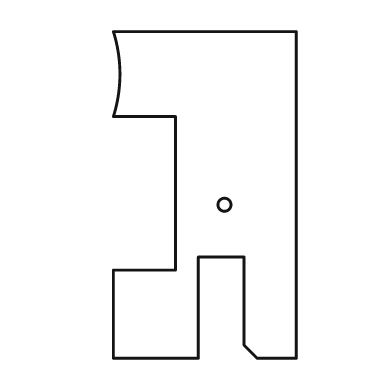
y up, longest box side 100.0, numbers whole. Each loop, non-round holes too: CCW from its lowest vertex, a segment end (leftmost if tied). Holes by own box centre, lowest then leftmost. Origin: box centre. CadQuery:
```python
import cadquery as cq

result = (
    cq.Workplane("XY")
    .moveTo(-28.0, -50.0)
    .lineTo(-2.0, -50.0)
    .lineTo(-2.0, -19.0)
    .lineTo(12.0, -19.0)
    .lineTo(12.0, -46.0)
    .lineTo(16.0, -50.0)
    .lineTo(28.0, -50.0)
    .lineTo(28.0, 50.0)
    .lineTo(-28.0, 50.0)
    .threePointArc((-26.0, 37.0), (-28.0, 24.0))
    .lineTo(-9.0, 24.0)
    .lineTo(-9.0, -23.0)
    .lineTo(-28.0, -23.0)
    .close()
    .moveTo(6.0, -3.0)
    .circle(2.0)
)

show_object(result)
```